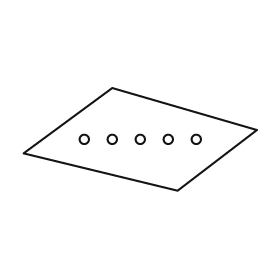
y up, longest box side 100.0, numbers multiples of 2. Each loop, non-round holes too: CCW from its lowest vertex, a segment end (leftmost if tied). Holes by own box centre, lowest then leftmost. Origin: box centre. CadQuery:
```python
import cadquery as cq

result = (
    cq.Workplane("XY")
    .moveTo(16.0, -22.0)
    .lineTo(50.0, 4.0)
    .lineTo(-12.0, 22.0)
    .lineTo(-50.0, -6.0)
    .close()
    .moveTo(-24.0, 0.0)
    .circle(2.0)
    .moveTo(-12.0, 0.0)
    .circle(2.0)
    .moveTo(0.0, 0.0)
    .circle(2.0)
    .moveTo(12.0, 0.0)
    .circle(2.0)
    .moveTo(24.0, 0.0)
    .circle(2.0)
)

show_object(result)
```